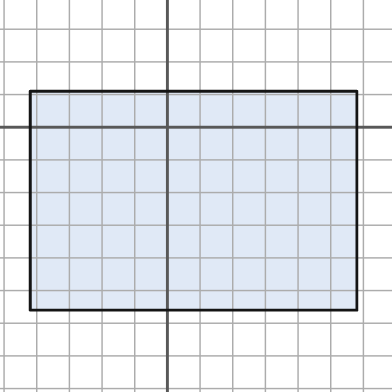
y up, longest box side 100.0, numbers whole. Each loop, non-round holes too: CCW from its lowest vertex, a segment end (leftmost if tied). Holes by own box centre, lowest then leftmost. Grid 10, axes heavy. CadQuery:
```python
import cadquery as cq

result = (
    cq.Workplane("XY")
    .moveTo(-42.0, -56.0)
    .lineTo(58.0, -56.0)
    .lineTo(58.0, 11.0)
    .lineTo(-42.0, 11.0)
    .close()
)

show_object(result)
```